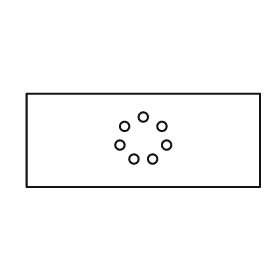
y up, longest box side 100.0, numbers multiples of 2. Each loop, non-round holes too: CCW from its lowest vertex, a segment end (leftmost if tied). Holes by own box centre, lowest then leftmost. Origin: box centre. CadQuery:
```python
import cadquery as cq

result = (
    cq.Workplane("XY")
    .moveTo(-50.0, -20.0)
    .lineTo(50.0, -20.0)
    .lineTo(50.0, 20.0)
    .lineTo(-50.0, 20.0)
    .close()
    .moveTo(-4.0, -8.0)
    .circle(2.0)
    .moveTo(4.0, -8.0)
    .circle(2.0)
    .moveTo(-10.0, -2.0)
    .circle(2.0)
    .moveTo(10.0, -2.0)
    .circle(2.0)
    .moveTo(-8.0, 6.0)
    .circle(2.0)
    .moveTo(8.0, 6.0)
    .circle(2.0)
    .moveTo(0.0, 10.0)
    .circle(2.0)
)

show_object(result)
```